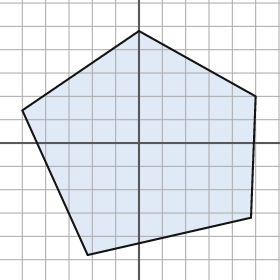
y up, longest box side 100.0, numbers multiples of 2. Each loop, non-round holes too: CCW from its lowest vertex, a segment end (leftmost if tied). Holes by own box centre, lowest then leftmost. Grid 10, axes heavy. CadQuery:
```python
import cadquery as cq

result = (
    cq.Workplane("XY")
    .moveTo(-22.0, -48.0)
    .lineTo(48.0, -32.0)
    .lineTo(50.0, 20.0)
    .lineTo(0.0, 48.0)
    .lineTo(-50.0, 14.0)
    .close()
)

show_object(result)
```